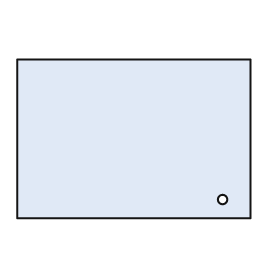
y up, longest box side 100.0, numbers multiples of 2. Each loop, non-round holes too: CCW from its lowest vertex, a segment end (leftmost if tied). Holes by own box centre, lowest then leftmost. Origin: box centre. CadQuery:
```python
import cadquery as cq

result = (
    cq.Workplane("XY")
    .moveTo(-50.0, -34.0)
    .lineTo(50.0, -34.0)
    .lineTo(50.0, 34.0)
    .lineTo(-50.0, 34.0)
    .close()
    .moveTo(38.0, -26.0)
    .circle(2.0)
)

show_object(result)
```